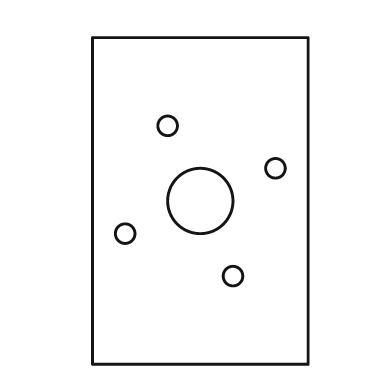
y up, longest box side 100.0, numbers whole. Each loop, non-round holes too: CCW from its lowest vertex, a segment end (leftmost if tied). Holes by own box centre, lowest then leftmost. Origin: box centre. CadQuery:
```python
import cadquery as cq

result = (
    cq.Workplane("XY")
    .moveTo(-33.0, -50.0)
    .lineTo(33.0, -50.0)
    .lineTo(33.0, 50.0)
    .lineTo(-33.0, 50.0)
    .close()
    .moveTo(10.0, -23.0)
    .circle(3.0)
    .moveTo(-23.0, -10.0)
    .circle(3.0)
    .moveTo(0.0, 0.0)
    .circle(10.0)
    .moveTo(23.0, 10.0)
    .circle(3.0)
    .moveTo(-10.0, 23.0)
    .circle(3.0)
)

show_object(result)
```